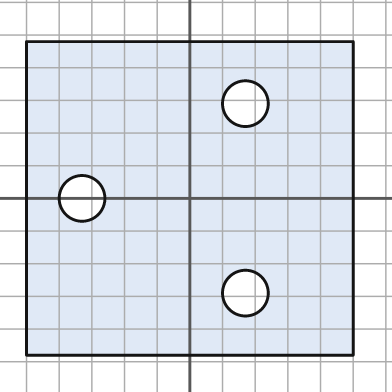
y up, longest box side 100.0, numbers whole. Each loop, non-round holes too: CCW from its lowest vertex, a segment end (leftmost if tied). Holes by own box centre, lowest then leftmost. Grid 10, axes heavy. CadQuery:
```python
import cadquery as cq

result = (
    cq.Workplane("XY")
    .moveTo(-50.0, -48.0)
    .lineTo(50.0, -48.0)
    .lineTo(50.0, 48.0)
    .lineTo(-50.0, 48.0)
    .close()
    .moveTo(17.0, -29.0)
    .circle(7.0)
    .moveTo(-33.0, 0.0)
    .circle(7.0)
    .moveTo(17.0, 29.0)
    .circle(7.0)
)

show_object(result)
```